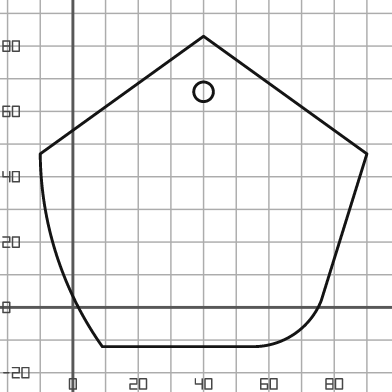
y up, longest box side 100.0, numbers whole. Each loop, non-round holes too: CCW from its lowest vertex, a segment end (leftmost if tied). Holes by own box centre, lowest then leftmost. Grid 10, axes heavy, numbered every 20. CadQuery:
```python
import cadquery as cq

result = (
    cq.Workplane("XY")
    .moveTo(9.0, -12.0)
    .lineTo(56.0, -12.0)
    .threePointArc((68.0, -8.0), (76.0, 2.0))
    .lineTo(90.0, 47.0)
    .lineTo(40.0, 83.0)
    .lineTo(-10.0, 47.0)
    .threePointArc((-5.0, 16.0), (9.0, -12.0))
    .close()
    .moveTo(40.0, 66.0)
    .circle(3.0)
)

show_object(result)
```